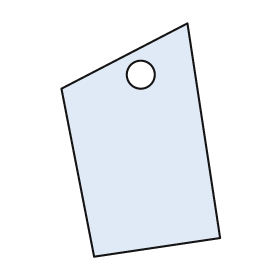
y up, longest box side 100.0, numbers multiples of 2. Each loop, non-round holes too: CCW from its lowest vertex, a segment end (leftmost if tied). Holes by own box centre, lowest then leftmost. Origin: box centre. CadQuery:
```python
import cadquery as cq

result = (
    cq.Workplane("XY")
    .moveTo(-20.0, -50.0)
    .lineTo(34.0, -42.0)
    .lineTo(20.0, 50.0)
    .lineTo(-34.0, 22.0)
    .close()
    .moveTo(0.0, 28.0)
    .circle(6.0)
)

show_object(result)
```